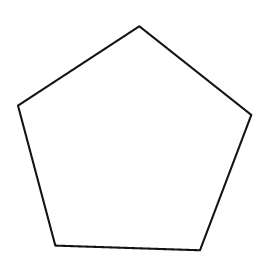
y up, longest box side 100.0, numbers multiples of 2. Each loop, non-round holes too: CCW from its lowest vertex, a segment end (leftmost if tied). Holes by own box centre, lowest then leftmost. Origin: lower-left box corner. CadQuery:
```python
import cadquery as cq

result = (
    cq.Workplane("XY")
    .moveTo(78.0, 0.0)
    .lineTo(100.0, 58.0)
    .lineTo(52.0, 96.0)
    .lineTo(0.0, 62.0)
    .lineTo(16.0, 2.0)
    .close()
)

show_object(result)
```